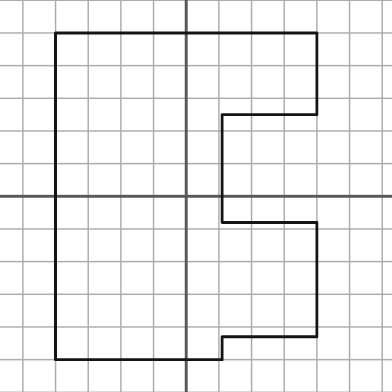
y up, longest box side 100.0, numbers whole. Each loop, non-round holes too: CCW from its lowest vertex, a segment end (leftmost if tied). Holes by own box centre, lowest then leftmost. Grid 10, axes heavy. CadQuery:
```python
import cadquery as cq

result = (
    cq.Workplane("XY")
    .moveTo(-40.0, -50.0)
    .lineTo(11.0, -50.0)
    .lineTo(11.0, -43.0)
    .lineTo(40.0, -43.0)
    .lineTo(40.0, -8.0)
    .lineTo(11.0, -8.0)
    .lineTo(11.0, 25.0)
    .lineTo(40.0, 25.0)
    .lineTo(40.0, 50.0)
    .lineTo(-40.0, 50.0)
    .close()
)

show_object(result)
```